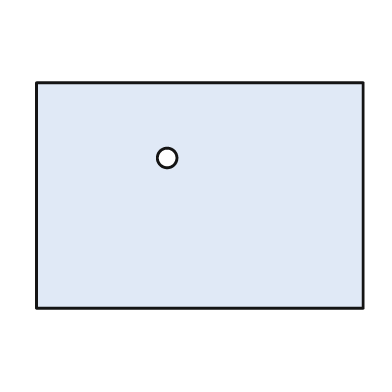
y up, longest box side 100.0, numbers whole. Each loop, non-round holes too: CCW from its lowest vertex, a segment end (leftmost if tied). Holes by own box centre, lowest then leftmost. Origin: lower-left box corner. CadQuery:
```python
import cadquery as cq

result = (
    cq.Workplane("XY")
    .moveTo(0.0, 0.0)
    .lineTo(100.0, 0.0)
    .lineTo(100.0, 69.0)
    .lineTo(0.0, 69.0)
    .close()
    .moveTo(40.0, 46.0)
    .circle(3.0)
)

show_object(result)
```